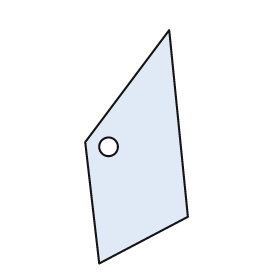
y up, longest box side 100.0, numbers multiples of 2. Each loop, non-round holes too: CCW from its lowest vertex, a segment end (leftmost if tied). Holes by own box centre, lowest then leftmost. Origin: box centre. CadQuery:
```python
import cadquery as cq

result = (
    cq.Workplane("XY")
    .moveTo(-16.0, -50.0)
    .lineTo(22.0, -30.0)
    .lineTo(14.0, 50.0)
    .lineTo(-22.0, 2.0)
    .close()
    .moveTo(-12.0, 0.0)
    .circle(4.0)
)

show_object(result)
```